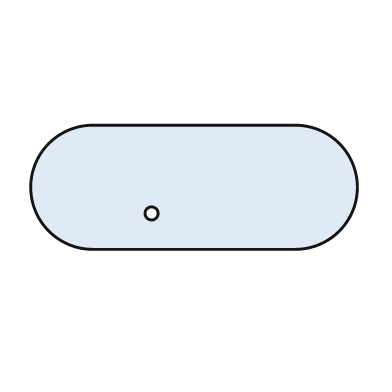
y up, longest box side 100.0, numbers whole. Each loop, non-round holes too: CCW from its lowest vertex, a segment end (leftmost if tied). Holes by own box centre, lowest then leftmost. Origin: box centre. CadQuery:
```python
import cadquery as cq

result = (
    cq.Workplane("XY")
    .moveTo(-31.0, -19.0)
    .lineTo(31.0, -19.0)
    .threePointArc((50.0, 0.0), (31.0, 19.0))
    .lineTo(-31.0, 19.0)
    .threePointArc((-50.0, 0.0), (-31.0, -19.0))
    .close()
    .moveTo(-13.0, -8.0)
    .circle(2.0)
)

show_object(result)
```